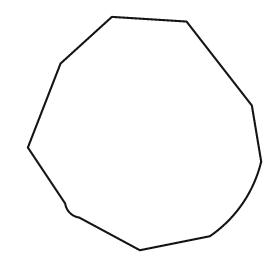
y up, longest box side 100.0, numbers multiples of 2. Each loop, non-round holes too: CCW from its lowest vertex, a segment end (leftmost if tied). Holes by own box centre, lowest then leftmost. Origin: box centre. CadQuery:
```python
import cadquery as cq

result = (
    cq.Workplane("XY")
    .moveTo(-2.0, -50.0)
    .lineTo(28.0, -44.0)
    .threePointArc((42.0, -30.0), (50.0, -12.0))
    .lineTo(46.0, 12.0)
    .lineTo(18.0, 48.0)
    .lineTo(-14.0, 50.0)
    .lineTo(-36.0, 30.0)
    .lineTo(-50.0, -6.0)
    .lineTo(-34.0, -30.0)
    .threePointArc((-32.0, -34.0), (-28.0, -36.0))
    .close()
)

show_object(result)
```